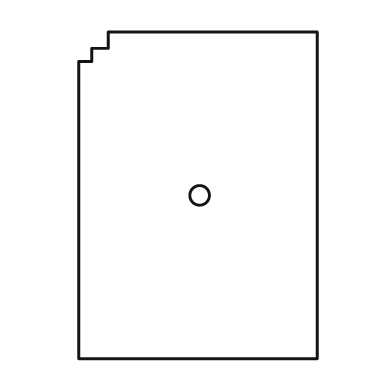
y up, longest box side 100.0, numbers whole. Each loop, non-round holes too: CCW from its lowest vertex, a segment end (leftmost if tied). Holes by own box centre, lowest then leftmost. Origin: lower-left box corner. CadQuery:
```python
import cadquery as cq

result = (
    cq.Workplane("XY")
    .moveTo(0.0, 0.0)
    .lineTo(73.0, 0.0)
    .lineTo(73.0, 100.0)
    .lineTo(9.0, 100.0)
    .lineTo(9.0, 95.0)
    .lineTo(4.0, 95.0)
    .lineTo(4.0, 91.0)
    .lineTo(0.0, 91.0)
    .close()
    .moveTo(37.0, 50.0)
    .circle(3.0)
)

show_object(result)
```